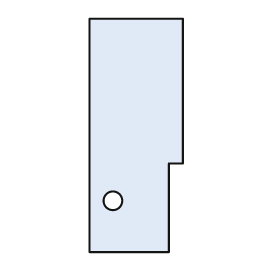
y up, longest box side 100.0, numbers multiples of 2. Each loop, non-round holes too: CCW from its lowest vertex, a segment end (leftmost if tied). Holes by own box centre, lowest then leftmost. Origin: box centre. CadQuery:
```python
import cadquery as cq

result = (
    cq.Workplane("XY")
    .moveTo(-20.0, -50.0)
    .lineTo(14.0, -50.0)
    .lineTo(14.0, -12.0)
    .lineTo(20.0, -12.0)
    .lineTo(20.0, 50.0)
    .lineTo(-20.0, 50.0)
    .close()
    .moveTo(-10.0, -28.0)
    .circle(4.0)
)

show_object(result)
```